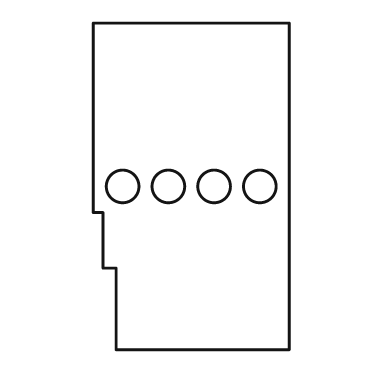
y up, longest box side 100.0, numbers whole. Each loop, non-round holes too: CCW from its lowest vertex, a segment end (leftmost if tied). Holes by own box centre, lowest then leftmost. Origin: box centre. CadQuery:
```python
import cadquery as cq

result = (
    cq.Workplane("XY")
    .moveTo(-23.0, -50.0)
    .lineTo(30.0, -50.0)
    .lineTo(30.0, 50.0)
    .lineTo(-30.0, 50.0)
    .lineTo(-30.0, -8.0)
    .lineTo(-27.0, -8.0)
    .lineTo(-27.0, -25.0)
    .lineTo(-23.0, -25.0)
    .close()
    .moveTo(-21.0, 0.0)
    .circle(5.0)
    .moveTo(-7.0, 0.0)
    .circle(5.0)
    .moveTo(7.0, 0.0)
    .circle(5.0)
    .moveTo(21.0, 0.0)
    .circle(5.0)
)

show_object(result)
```